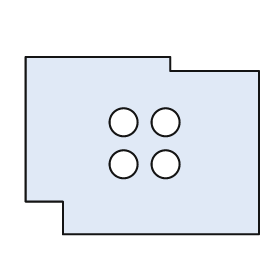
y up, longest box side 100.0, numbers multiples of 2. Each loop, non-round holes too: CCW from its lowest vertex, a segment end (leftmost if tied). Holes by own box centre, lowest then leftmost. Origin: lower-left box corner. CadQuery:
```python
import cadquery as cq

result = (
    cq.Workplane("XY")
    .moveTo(16.0, 0.0)
    .lineTo(100.0, 0.0)
    .lineTo(100.0, 70.0)
    .lineTo(62.0, 70.0)
    .lineTo(62.0, 76.0)
    .lineTo(0.0, 76.0)
    .lineTo(0.0, 14.0)
    .lineTo(16.0, 14.0)
    .close()
    .moveTo(42.0, 30.0)
    .circle(6.0)
    .moveTo(60.0, 30.0)
    .circle(6.0)
    .moveTo(42.0, 48.0)
    .circle(6.0)
    .moveTo(60.0, 48.0)
    .circle(6.0)
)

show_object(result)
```